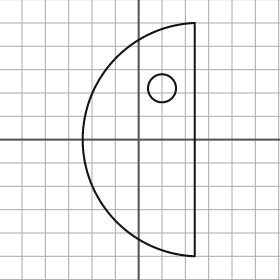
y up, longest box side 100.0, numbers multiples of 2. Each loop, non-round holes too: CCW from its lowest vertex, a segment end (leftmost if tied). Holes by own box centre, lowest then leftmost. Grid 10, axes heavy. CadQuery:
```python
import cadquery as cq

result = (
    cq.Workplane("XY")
    .moveTo(24.0, -50.0)
    .lineTo(24.0, 50.0)
    .threePointArc((-24.0, 0.0), (24.0, -50.0))
    .close()
    .moveTo(10.0, 22.0)
    .circle(6.0)
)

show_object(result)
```